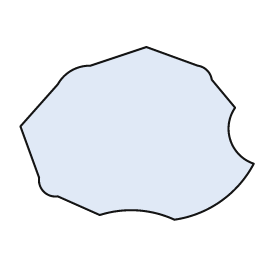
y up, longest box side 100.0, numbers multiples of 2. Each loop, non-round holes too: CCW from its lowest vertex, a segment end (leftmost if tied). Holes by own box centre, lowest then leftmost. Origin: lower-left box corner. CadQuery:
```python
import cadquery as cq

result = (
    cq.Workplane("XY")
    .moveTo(66.0, 0.0)
    .threePointArc((86.0, 8.0), (100.0, 24.0))
    .threePointArc((90.0, 34.0), (92.0, 48.0))
    .lineTo(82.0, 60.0)
    .threePointArc((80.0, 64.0), (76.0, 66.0))
    .lineTo(54.0, 74.0)
    .lineTo(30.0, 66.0)
    .threePointArc((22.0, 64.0), (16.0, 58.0))
    .lineTo(0.0, 40.0)
    .lineTo(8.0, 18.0)
    .threePointArc((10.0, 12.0), (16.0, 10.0))
    .lineTo(34.0, 2.0)
    .threePointArc((50.0, 4.0), (66.0, 0.0))
    .close()
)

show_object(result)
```